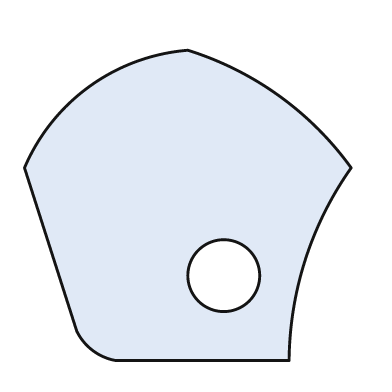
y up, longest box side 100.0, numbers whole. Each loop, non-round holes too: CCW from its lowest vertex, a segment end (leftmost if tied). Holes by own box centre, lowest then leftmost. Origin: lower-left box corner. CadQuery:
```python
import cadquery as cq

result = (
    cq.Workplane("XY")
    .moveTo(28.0, 0.0)
    .lineTo(81.0, 0.0)
    .threePointArc((86.0, 31.0), (100.0, 59.0))
    .threePointArc((78.0, 81.0), (50.0, 95.0))
    .threePointArc((20.0, 84.0), (0.0, 59.0))
    .lineTo(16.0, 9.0)
    .threePointArc((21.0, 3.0), (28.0, 0.0))
    .close()
    .moveTo(61.0, 26.0)
    .circle(11.0)
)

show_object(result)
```